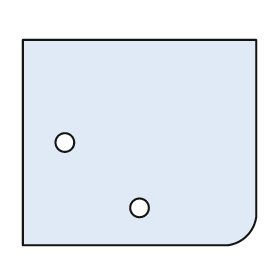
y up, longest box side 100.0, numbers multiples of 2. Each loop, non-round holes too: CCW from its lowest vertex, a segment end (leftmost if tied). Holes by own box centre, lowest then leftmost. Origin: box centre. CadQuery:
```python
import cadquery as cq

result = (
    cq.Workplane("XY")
    .moveTo(-50.0, -44.0)
    .lineTo(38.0, -44.0)
    .threePointArc((46.0, -40.0), (50.0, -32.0))
    .lineTo(50.0, 44.0)
    .lineTo(-50.0, 44.0)
    .close()
    .moveTo(0.0, -28.0)
    .circle(4.0)
    .moveTo(-32.0, 0.0)
    .circle(4.0)
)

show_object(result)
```